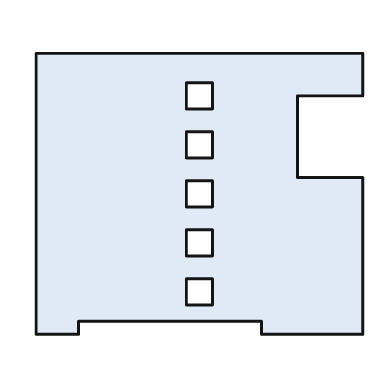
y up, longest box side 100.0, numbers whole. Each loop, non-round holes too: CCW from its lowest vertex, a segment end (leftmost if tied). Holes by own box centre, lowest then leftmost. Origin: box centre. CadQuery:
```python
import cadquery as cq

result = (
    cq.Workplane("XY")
    .moveTo(-50.0, -43.0)
    .lineTo(-37.0, -43.0)
    .lineTo(-37.0, -39.0)
    .lineTo(19.0, -39.0)
    .lineTo(19.0, -43.0)
    .lineTo(50.0, -43.0)
    .lineTo(50.0, 5.0)
    .lineTo(30.0, 5.0)
    .lineTo(30.0, 30.0)
    .lineTo(50.0, 30.0)
    .lineTo(50.0, 43.0)
    .lineTo(-50.0, 43.0)
    .close()
    .moveTo(-4.0, -34.0)
    .lineTo(4.0, -34.0)
    .lineTo(4.0, -26.0)
    .lineTo(-4.0, -26.0)
    .close()
    .moveTo(-4.0, -19.0)
    .lineTo(4.0, -19.0)
    .lineTo(4.0, -11.0)
    .lineTo(-4.0, -11.0)
    .close()
    .moveTo(-4.0, -4.0)
    .lineTo(4.0, -4.0)
    .lineTo(4.0, 4.0)
    .lineTo(-4.0, 4.0)
    .close()
    .moveTo(-4.0, 11.0)
    .lineTo(4.0, 11.0)
    .lineTo(4.0, 19.0)
    .lineTo(-4.0, 19.0)
    .close()
    .moveTo(-4.0, 26.0)
    .lineTo(4.0, 26.0)
    .lineTo(4.0, 34.0)
    .lineTo(-4.0, 34.0)
    .close()
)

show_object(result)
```